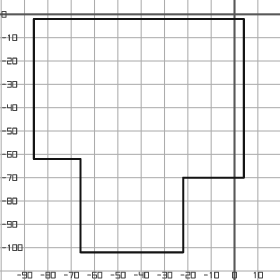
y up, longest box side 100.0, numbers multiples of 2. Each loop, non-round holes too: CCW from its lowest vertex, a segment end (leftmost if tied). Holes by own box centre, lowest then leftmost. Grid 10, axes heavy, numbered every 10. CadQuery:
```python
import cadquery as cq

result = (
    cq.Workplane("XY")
    .moveTo(-66.0, -102.0)
    .lineTo(-22.0, -102.0)
    .lineTo(-22.0, -70.0)
    .lineTo(4.0, -70.0)
    .lineTo(4.0, -2.0)
    .lineTo(-86.0, -2.0)
    .lineTo(-86.0, -62.0)
    .lineTo(-66.0, -62.0)
    .close()
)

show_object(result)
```